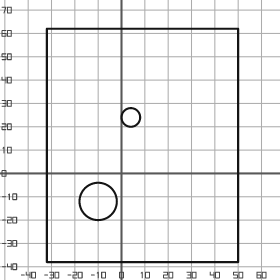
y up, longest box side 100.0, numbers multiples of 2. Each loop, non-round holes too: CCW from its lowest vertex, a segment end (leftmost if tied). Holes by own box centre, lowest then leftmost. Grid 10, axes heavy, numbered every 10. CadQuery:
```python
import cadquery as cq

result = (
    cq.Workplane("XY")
    .moveTo(-32.0, -38.0)
    .lineTo(50.0, -38.0)
    .lineTo(50.0, 62.0)
    .lineTo(-32.0, 62.0)
    .close()
    .moveTo(-10.0, -12.0)
    .circle(8.0)
    .moveTo(4.0, 24.0)
    .circle(4.0)
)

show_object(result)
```